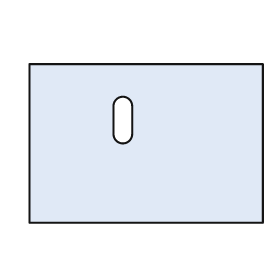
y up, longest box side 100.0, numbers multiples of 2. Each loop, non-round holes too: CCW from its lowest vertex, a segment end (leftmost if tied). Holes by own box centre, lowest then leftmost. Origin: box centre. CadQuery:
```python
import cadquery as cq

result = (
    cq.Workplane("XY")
    .moveTo(-50.0, -34.0)
    .lineTo(50.0, -34.0)
    .lineTo(50.0, 34.0)
    .lineTo(-50.0, 34.0)
    .close()
    .moveTo(-14.0, 4.0)
    .threePointArc((-10.0, 0.0), (-6.0, 4.0))
    .lineTo(-6.0, 16.0)
    .threePointArc((-10.0, 20.0), (-14.0, 16.0))
    .close()
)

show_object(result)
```